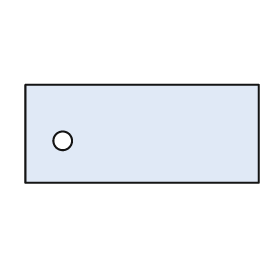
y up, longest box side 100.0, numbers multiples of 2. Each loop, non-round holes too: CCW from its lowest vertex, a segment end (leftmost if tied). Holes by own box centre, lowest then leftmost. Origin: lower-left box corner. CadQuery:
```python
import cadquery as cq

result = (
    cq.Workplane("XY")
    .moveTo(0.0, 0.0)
    .lineTo(100.0, 0.0)
    .lineTo(100.0, 42.0)
    .lineTo(0.0, 42.0)
    .close()
    .moveTo(16.0, 18.0)
    .circle(4.0)
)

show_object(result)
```